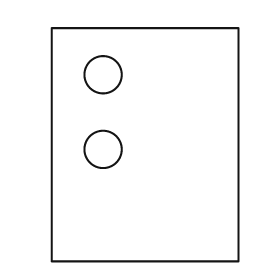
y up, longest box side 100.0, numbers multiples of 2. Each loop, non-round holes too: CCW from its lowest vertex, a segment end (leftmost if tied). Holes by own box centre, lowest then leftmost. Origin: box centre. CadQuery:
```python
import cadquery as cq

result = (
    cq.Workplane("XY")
    .moveTo(-40.0, -50.0)
    .lineTo(40.0, -50.0)
    .lineTo(40.0, 50.0)
    .lineTo(-40.0, 50.0)
    .close()
    .moveTo(-18.0, -2.0)
    .circle(8.0)
    .moveTo(-18.0, 30.0)
    .circle(8.0)
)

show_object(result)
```